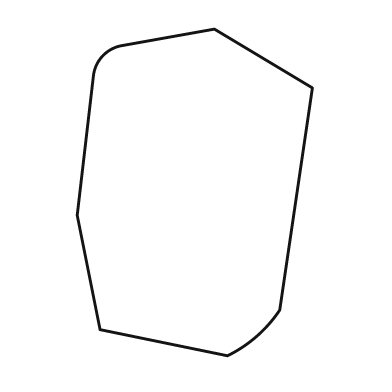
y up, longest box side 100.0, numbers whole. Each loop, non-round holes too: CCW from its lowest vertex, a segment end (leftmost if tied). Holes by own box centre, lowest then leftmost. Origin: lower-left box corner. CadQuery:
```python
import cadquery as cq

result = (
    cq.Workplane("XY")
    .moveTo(46.0, 0.0)
    .threePointArc((55.0, 6.0), (62.0, 14.0))
    .lineTo(72.0, 82.0)
    .lineTo(42.0, 100.0)
    .lineTo(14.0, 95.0)
    .threePointArc((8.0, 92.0), (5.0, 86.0))
    .lineTo(0.0, 43.0)
    .lineTo(7.0, 8.0)
    .close()
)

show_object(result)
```